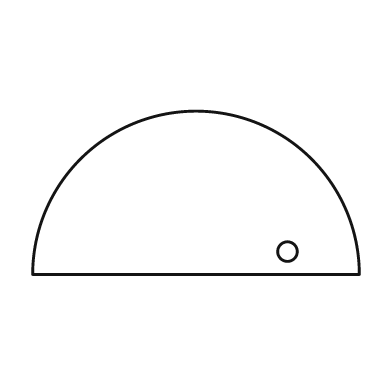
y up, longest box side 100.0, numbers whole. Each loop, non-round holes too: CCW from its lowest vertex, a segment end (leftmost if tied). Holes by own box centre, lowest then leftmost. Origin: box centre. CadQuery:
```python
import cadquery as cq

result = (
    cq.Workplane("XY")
    .moveTo(-50.0, -25.0)
    .lineTo(50.0, -25.0)
    .threePointArc((0.0, 25.0), (-50.0, -25.0))
    .close()
    .moveTo(28.0, -18.0)
    .circle(3.0)
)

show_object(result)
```